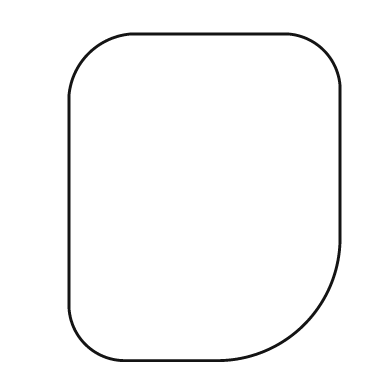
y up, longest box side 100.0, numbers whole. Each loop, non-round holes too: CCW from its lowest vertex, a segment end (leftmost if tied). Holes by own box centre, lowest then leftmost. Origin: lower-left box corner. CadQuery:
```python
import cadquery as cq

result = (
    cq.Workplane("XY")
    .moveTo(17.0, 0.0)
    .lineTo(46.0, 0.0)
    .threePointArc((72.0, 11.0), (83.0, 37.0))
    .lineTo(83.0, 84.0)
    .threePointArc((78.0, 95.0), (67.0, 100.0))
    .lineTo(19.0, 100.0)
    .threePointArc((6.0, 94.0), (0.0, 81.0))
    .lineTo(0.0, 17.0)
    .threePointArc((5.0, 5.0), (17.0, 0.0))
    .close()
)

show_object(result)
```